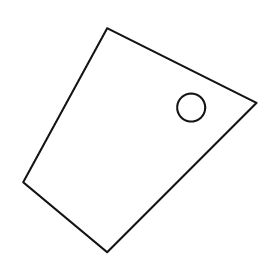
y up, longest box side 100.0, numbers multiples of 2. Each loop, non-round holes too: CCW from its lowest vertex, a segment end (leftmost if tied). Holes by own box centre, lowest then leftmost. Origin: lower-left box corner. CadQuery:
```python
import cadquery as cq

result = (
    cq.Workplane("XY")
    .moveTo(36.0, 0.0)
    .lineTo(100.0, 64.0)
    .lineTo(36.0, 96.0)
    .lineTo(0.0, 30.0)
    .close()
    .moveTo(72.0, 62.0)
    .circle(6.0)
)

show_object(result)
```